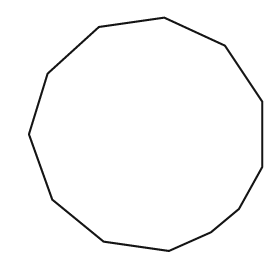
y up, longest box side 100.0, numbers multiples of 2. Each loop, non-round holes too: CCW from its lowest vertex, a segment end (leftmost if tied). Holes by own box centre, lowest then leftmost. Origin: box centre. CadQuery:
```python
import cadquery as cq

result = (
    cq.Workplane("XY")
    .moveTo(10.0, -50.0)
    .lineTo(28.0, -42.0)
    .lineTo(40.0, -32.0)
    .lineTo(50.0, -14.0)
    .lineTo(50.0, 14.0)
    .lineTo(34.0, 38.0)
    .lineTo(8.0, 50.0)
    .lineTo(-20.0, 46.0)
    .lineTo(-42.0, 26.0)
    .lineTo(-50.0, 0.0)
    .lineTo(-40.0, -28.0)
    .lineTo(-18.0, -46.0)
    .close()
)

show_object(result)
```